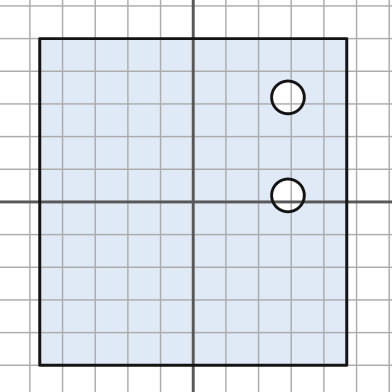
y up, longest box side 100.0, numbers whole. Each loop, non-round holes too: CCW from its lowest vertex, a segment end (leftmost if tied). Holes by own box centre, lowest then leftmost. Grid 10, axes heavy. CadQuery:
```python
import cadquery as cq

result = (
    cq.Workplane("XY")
    .moveTo(-47.0, -50.0)
    .lineTo(47.0, -50.0)
    .lineTo(47.0, 50.0)
    .lineTo(-47.0, 50.0)
    .close()
    .moveTo(29.0, 2.0)
    .circle(5.0)
    .moveTo(29.0, 32.0)
    .circle(5.0)
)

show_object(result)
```